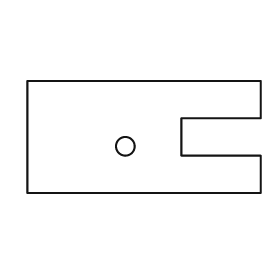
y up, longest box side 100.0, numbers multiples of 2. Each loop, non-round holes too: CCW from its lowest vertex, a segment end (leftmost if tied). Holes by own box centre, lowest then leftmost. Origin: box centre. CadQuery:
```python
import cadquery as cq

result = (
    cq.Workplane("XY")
    .moveTo(-50.0, -24.0)
    .lineTo(50.0, -24.0)
    .lineTo(50.0, -8.0)
    .lineTo(16.0, -8.0)
    .lineTo(16.0, 8.0)
    .lineTo(50.0, 8.0)
    .lineTo(50.0, 24.0)
    .lineTo(-50.0, 24.0)
    .close()
    .moveTo(-8.0, -4.0)
    .circle(4.0)
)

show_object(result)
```